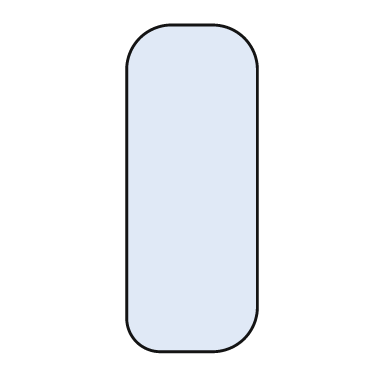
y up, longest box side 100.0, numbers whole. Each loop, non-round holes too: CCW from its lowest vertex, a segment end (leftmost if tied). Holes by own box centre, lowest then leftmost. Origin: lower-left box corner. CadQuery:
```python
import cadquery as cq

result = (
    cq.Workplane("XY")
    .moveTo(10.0, 0.0)
    .lineTo(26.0, 0.0)
    .threePointArc((36.0, 4.0), (40.0, 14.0))
    .lineTo(40.0, 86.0)
    .threePointArc((36.0, 96.0), (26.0, 100.0))
    .lineTo(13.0, 100.0)
    .threePointArc((4.0, 96.0), (0.0, 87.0))
    .lineTo(0.0, 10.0)
    .threePointArc((3.0, 3.0), (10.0, 0.0))
    .close()
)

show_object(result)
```